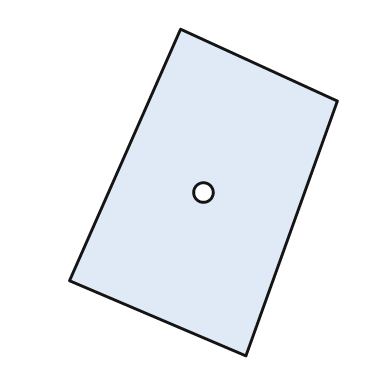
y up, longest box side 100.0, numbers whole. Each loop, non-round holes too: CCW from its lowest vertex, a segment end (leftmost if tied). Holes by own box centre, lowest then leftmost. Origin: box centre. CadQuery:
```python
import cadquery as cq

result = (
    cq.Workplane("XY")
    .moveTo(13.0, -50.0)
    .lineTo(41.0, 28.0)
    .lineTo(-7.0, 50.0)
    .lineTo(-41.0, -27.0)
    .close()
    .moveTo(0.0, 0.0)
    .circle(3.0)
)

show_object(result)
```